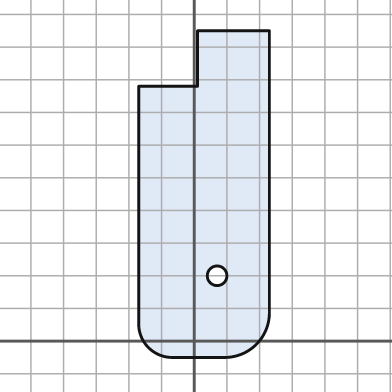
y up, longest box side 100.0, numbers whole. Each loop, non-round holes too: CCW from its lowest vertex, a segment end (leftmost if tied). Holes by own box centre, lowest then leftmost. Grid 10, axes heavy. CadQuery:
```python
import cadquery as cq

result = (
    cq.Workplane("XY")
    .moveTo(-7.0, -5.0)
    .lineTo(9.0, -5.0)
    .threePointArc((19.0, -1.0), (23.0, 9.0))
    .lineTo(23.0, 95.0)
    .lineTo(1.0, 95.0)
    .lineTo(1.0, 78.0)
    .lineTo(-17.0, 78.0)
    .lineTo(-17.0, 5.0)
    .threePointArc((-14.0, -2.0), (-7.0, -5.0))
    .close()
    .moveTo(7.0, 20.0)
    .circle(3.0)
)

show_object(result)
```